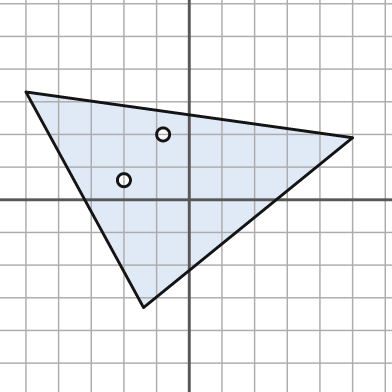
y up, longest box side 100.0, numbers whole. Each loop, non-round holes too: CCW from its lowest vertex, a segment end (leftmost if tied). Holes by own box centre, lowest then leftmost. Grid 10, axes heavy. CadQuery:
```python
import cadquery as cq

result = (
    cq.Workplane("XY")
    .moveTo(-14.0, -33.0)
    .lineTo(50.0, 19.0)
    .lineTo(-50.0, 33.0)
    .close()
    .moveTo(-20.0, 6.0)
    .circle(2.0)
    .moveTo(-8.0, 20.0)
    .circle(2.0)
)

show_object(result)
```